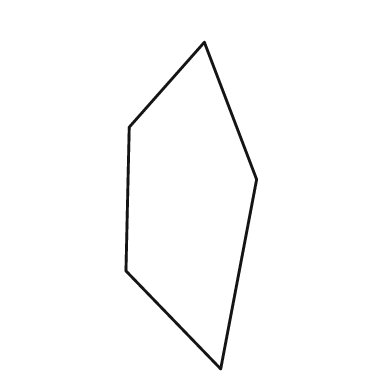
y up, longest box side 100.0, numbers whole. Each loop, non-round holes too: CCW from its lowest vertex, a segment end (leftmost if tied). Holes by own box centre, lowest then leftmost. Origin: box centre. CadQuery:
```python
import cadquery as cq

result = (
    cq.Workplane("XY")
    .moveTo(9.0, -50.0)
    .lineTo(20.0, 8.0)
    .lineTo(4.0, 50.0)
    .lineTo(-19.0, 24.0)
    .lineTo(-20.0, -20.0)
    .close()
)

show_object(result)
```